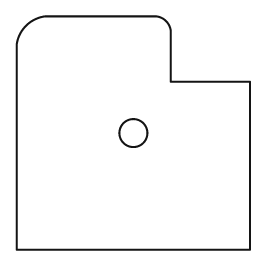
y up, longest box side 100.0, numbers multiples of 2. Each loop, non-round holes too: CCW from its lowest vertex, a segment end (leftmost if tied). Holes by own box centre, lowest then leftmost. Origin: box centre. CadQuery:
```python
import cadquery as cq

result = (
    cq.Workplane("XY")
    .moveTo(-50.0, -50.0)
    .lineTo(50.0, -50.0)
    .lineTo(50.0, 22.0)
    .lineTo(16.0, 22.0)
    .lineTo(16.0, 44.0)
    .threePointArc((14.0, 48.0), (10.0, 50.0))
    .lineTo(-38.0, 50.0)
    .threePointArc((-46.0, 46.0), (-50.0, 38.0))
    .close()
    .moveTo(0.0, 0.0)
    .circle(6.0)
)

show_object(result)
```